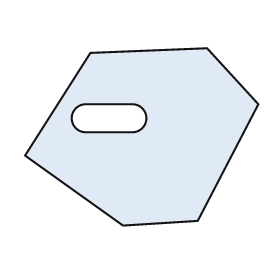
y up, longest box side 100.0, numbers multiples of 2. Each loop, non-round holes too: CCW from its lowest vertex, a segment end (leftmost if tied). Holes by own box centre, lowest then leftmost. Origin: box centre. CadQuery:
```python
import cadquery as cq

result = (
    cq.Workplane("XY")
    .moveTo(-8.0, -38.0)
    .lineTo(24.0, -36.0)
    .lineTo(50.0, 14.0)
    .lineTo(28.0, 38.0)
    .lineTo(-22.0, 36.0)
    .lineTo(-50.0, -8.0)
    .close()
    .moveTo(-24.0, 2.0)
    .lineTo(-4.0, 2.0)
    .threePointArc((2.0, 8.0), (-4.0, 14.0))
    .lineTo(-24.0, 14.0)
    .threePointArc((-30.0, 8.0), (-24.0, 2.0))
    .close()
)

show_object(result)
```